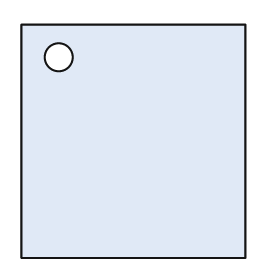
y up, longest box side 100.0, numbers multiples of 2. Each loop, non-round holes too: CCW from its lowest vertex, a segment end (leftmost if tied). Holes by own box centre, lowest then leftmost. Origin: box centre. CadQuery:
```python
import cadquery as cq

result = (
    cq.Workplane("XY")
    .moveTo(-48.0, -50.0)
    .lineTo(48.0, -50.0)
    .lineTo(48.0, 50.0)
    .lineTo(-48.0, 50.0)
    .close()
    .moveTo(-32.0, 36.0)
    .circle(6.0)
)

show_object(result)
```